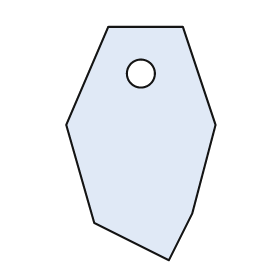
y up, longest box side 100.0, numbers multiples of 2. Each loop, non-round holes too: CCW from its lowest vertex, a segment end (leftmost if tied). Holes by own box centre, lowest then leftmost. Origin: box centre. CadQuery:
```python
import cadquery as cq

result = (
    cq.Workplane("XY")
    .moveTo(12.0, -50.0)
    .lineTo(22.0, -30.0)
    .lineTo(32.0, 8.0)
    .lineTo(18.0, 50.0)
    .lineTo(-14.0, 50.0)
    .lineTo(-32.0, 8.0)
    .lineTo(-20.0, -34.0)
    .close()
    .moveTo(0.0, 30.0)
    .circle(6.0)
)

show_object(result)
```